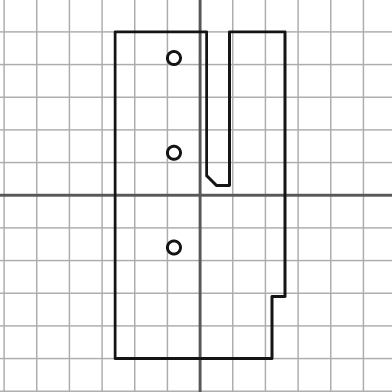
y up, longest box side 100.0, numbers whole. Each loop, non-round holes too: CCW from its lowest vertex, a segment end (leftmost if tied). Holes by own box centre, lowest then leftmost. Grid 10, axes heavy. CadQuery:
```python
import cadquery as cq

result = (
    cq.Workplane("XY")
    .moveTo(-26.0, -50.0)
    .lineTo(22.0, -50.0)
    .lineTo(22.0, -31.0)
    .lineTo(26.0, -31.0)
    .lineTo(26.0, 50.0)
    .lineTo(9.0, 50.0)
    .lineTo(9.0, 3.0)
    .lineTo(5.0, 3.0)
    .lineTo(2.0, 6.0)
    .lineTo(2.0, 50.0)
    .lineTo(-26.0, 50.0)
    .close()
    .moveTo(-8.0, -16.0)
    .circle(2.0)
    .moveTo(-8.0, 13.0)
    .circle(2.0)
    .moveTo(-8.0, 42.0)
    .circle(2.0)
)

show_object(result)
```